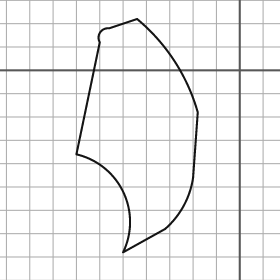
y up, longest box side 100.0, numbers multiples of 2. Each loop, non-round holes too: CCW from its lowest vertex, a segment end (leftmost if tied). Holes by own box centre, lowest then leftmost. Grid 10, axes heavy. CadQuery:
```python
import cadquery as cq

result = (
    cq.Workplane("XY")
    .moveTo(-50.0, -78.0)
    .lineTo(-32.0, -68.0)
    .threePointArc((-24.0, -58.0), (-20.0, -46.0))
    .lineTo(-18.0, -18.0)
    .threePointArc((-28.0, 4.0), (-44.0, 22.0))
    .lineTo(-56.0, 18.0)
    .threePointArc((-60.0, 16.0), (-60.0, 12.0))
    .lineTo(-70.0, -36.0)
    .threePointArc((-50.0, -52.0), (-50.0, -78.0))
    .close()
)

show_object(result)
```